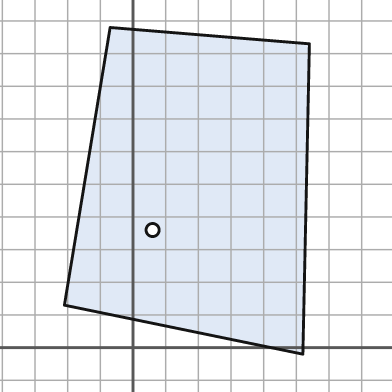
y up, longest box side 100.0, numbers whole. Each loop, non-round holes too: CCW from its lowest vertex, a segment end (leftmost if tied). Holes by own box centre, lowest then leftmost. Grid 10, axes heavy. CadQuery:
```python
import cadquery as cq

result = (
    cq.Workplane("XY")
    .moveTo(52.0, -2.0)
    .lineTo(54.0, 93.0)
    .lineTo(-7.0, 98.0)
    .lineTo(-21.0, 13.0)
    .close()
    .moveTo(6.0, 36.0)
    .circle(2.0)
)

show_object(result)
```